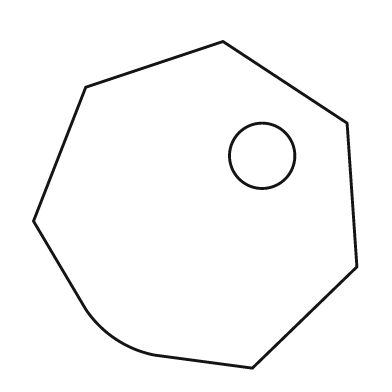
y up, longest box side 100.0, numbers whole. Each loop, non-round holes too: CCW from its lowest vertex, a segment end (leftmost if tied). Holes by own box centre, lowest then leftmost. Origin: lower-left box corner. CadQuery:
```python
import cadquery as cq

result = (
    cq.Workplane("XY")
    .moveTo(67.0, 0.0)
    .lineTo(99.0, 31.0)
    .lineTo(96.0, 75.0)
    .lineTo(58.0, 100.0)
    .lineTo(16.0, 86.0)
    .lineTo(0.0, 45.0)
    .lineTo(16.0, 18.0)
    .threePointArc((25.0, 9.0), (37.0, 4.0))
    .close()
    .moveTo(70.0, 65.0)
    .circle(10.0)
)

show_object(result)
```